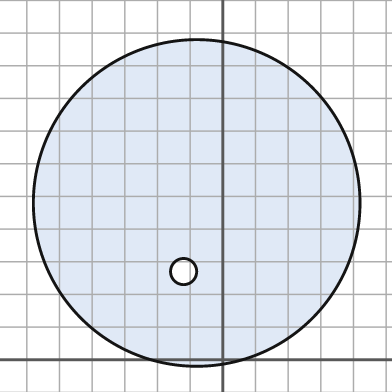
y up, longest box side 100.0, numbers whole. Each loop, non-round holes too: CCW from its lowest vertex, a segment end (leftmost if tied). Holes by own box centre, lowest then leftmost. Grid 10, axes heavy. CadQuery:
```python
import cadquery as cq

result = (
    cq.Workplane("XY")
    .moveTo(-8.0, 48.0)
    .circle(50.0)
    .moveTo(-12.0, 27.0)
    .circle(4.0)
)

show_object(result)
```